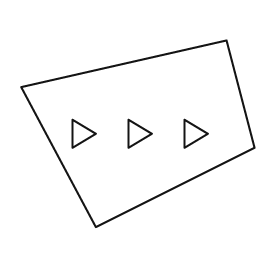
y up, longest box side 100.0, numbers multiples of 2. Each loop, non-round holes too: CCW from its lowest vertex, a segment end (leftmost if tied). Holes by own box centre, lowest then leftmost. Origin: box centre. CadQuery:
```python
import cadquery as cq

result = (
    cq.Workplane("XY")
    .moveTo(-18.0, -40.0)
    .lineTo(50.0, -6.0)
    .lineTo(38.0, 40.0)
    .lineTo(-50.0, 20.0)
    .close()
    .moveTo(-28.0, -6.0)
    .lineTo(-18.0, 0.0)
    .lineTo(-28.0, 6.0)
    .close()
    .moveTo(-4.0, -6.0)
    .lineTo(6.0, 0.0)
    .lineTo(-4.0, 6.0)
    .close()
    .moveTo(20.0, -6.0)
    .lineTo(30.0, 0.0)
    .lineTo(20.0, 6.0)
    .close()
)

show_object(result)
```